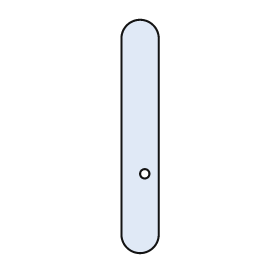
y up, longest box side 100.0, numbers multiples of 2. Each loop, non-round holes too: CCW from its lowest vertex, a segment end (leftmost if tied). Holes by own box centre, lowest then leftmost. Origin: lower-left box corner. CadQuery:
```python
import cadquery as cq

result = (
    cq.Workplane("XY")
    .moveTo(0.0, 8.0)
    .threePointArc((8.0, 0.0), (16.0, 8.0))
    .lineTo(16.0, 92.0)
    .threePointArc((8.0, 100.0), (0.0, 92.0))
    .close()
    .moveTo(10.0, 34.0)
    .circle(2.0)
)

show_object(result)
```